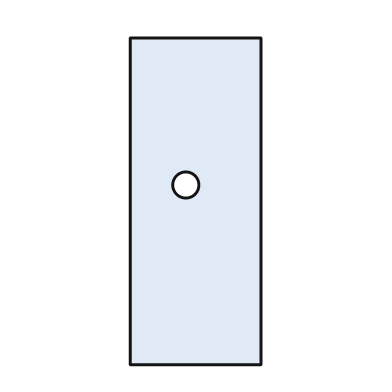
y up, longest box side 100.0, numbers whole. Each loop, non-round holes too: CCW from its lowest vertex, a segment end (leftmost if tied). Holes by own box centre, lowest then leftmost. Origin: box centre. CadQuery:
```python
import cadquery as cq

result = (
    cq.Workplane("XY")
    .moveTo(-20.0, -50.0)
    .lineTo(20.0, -50.0)
    .lineTo(20.0, 50.0)
    .lineTo(-20.0, 50.0)
    .close()
    .moveTo(-3.0, 5.0)
    .circle(4.0)
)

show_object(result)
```